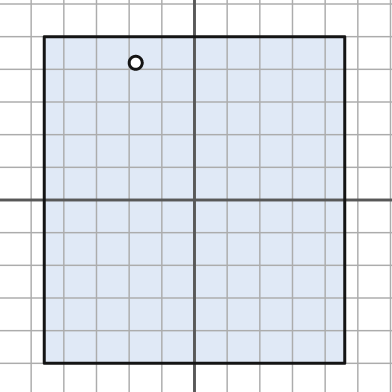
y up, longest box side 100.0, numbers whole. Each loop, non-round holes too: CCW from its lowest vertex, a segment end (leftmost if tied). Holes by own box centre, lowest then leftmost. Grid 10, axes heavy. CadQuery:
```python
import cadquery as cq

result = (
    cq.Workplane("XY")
    .moveTo(-46.0, -50.0)
    .lineTo(46.0, -50.0)
    .lineTo(46.0, 50.0)
    .lineTo(-46.0, 50.0)
    .close()
    .moveTo(-18.0, 42.0)
    .circle(2.0)
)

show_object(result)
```